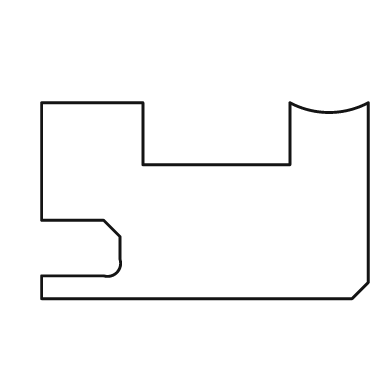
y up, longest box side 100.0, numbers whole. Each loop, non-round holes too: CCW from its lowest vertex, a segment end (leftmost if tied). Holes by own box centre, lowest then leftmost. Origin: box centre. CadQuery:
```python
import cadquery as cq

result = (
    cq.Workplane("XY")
    .moveTo(-50.0, -30.0)
    .lineTo(45.0, -30.0)
    .lineTo(50.0, -25.0)
    .lineTo(50.0, 30.0)
    .threePointArc((38.0, 27.0), (26.0, 30.0))
    .lineTo(26.0, 11.0)
    .lineTo(-19.0, 11.0)
    .lineTo(-19.0, 30.0)
    .lineTo(-50.0, 30.0)
    .lineTo(-50.0, -6.0)
    .lineTo(-31.0, -6.0)
    .lineTo(-26.0, -11.0)
    .lineTo(-26.0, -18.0)
    .threePointArc((-27.0, -22.0), (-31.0, -23.0))
    .lineTo(-50.0, -23.0)
    .close()
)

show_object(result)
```